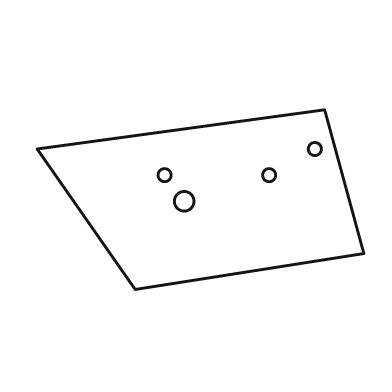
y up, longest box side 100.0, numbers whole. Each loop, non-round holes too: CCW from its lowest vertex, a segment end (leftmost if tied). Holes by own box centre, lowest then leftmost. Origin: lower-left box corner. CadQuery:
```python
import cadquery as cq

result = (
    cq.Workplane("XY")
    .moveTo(30.0, 0.0)
    .lineTo(100.0, 11.0)
    .lineTo(88.0, 55.0)
    .lineTo(0.0, 43.0)
    .close()
    .moveTo(45.0, 27.0)
    .circle(3.0)
    .moveTo(39.0, 35.0)
    .circle(2.0)
    .moveTo(71.0, 35.0)
    .circle(2.0)
    .moveTo(85.0, 43.0)
    .circle(2.0)
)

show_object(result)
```